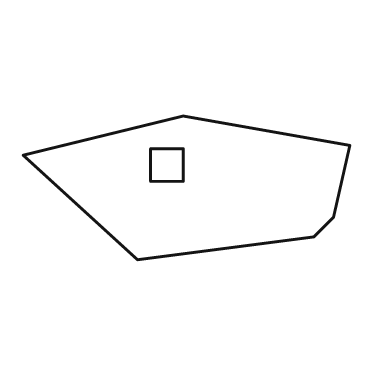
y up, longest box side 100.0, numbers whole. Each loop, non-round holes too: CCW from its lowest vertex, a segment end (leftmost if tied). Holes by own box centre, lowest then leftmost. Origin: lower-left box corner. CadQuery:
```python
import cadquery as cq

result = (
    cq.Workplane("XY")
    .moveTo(35.0, 0.0)
    .lineTo(89.0, 7.0)
    .lineTo(95.0, 13.0)
    .lineTo(100.0, 35.0)
    .lineTo(49.0, 44.0)
    .lineTo(0.0, 32.0)
    .close()
    .moveTo(39.0, 24.0)
    .lineTo(49.0, 24.0)
    .lineTo(49.0, 34.0)
    .lineTo(39.0, 34.0)
    .close()
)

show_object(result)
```